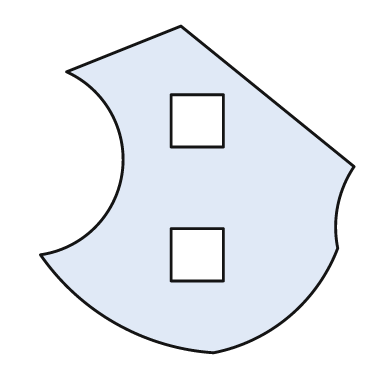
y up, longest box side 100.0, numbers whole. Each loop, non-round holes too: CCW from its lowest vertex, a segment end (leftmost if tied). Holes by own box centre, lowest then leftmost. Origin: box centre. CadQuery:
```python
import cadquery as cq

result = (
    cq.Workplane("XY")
    .moveTo(5.0, -50.0)
    .threePointArc((28.0, -39.0), (43.0, -18.0))
    .threePointArc((43.0, -5.0), (48.0, 7.0))
    .lineTo(-5.0, 50.0)
    .lineTo(-40.0, 36.0)
    .threePointArc((-23.0, 5.0), (-48.0, -20.0))
    .threePointArc((-25.0, -41.0), (5.0, -50.0))
    .close()
    .moveTo(-8.0, -28.0)
    .lineTo(8.0, -28.0)
    .lineTo(8.0, -12.0)
    .lineTo(-8.0, -12.0)
    .close()
    .moveTo(-8.0, 13.0)
    .lineTo(8.0, 13.0)
    .lineTo(8.0, 29.0)
    .lineTo(-8.0, 29.0)
    .close()
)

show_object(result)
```